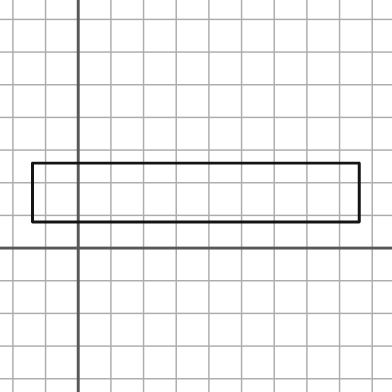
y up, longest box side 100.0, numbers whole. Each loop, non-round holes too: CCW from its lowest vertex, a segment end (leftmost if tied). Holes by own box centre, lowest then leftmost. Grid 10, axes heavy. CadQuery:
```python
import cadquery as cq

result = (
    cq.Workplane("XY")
    .moveTo(-14.0, 8.0)
    .lineTo(86.0, 8.0)
    .lineTo(86.0, 26.0)
    .lineTo(-14.0, 26.0)
    .close()
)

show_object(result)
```